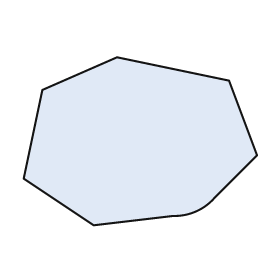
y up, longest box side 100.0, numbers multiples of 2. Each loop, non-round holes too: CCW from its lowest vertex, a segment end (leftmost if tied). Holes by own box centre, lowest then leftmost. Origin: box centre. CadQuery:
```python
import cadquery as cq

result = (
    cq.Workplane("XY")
    .moveTo(-20.0, -36.0)
    .lineTo(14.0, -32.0)
    .threePointArc((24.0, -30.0), (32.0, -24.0))
    .lineTo(50.0, -6.0)
    .lineTo(38.0, 26.0)
    .lineTo(-10.0, 36.0)
    .lineTo(-42.0, 22.0)
    .lineTo(-50.0, -16.0)
    .close()
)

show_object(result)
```